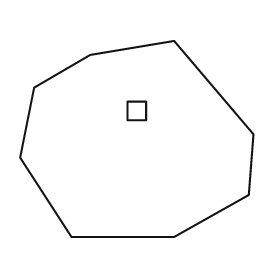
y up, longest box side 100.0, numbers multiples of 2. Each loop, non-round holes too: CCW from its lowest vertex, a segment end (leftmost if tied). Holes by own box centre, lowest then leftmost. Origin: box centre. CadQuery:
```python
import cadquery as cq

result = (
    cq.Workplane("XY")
    .moveTo(-28.0, -42.0)
    .lineTo(16.0, -42.0)
    .lineTo(48.0, -24.0)
    .lineTo(50.0, 2.0)
    .lineTo(16.0, 42.0)
    .lineTo(-20.0, 36.0)
    .lineTo(-44.0, 22.0)
    .lineTo(-50.0, -8.0)
    .close()
    .moveTo(-4.0, 8.0)
    .lineTo(4.0, 8.0)
    .lineTo(4.0, 16.0)
    .lineTo(-4.0, 16.0)
    .close()
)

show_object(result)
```